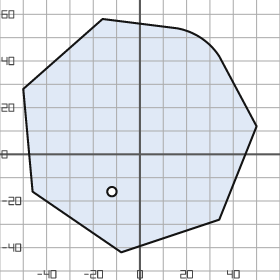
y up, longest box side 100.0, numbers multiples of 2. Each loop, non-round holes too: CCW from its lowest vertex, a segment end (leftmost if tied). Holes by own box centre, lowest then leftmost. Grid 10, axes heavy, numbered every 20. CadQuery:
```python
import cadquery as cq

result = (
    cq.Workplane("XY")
    .moveTo(-8.0, -42.0)
    .lineTo(34.0, -28.0)
    .lineTo(50.0, 12.0)
    .lineTo(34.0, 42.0)
    .threePointArc((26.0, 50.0), (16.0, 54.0))
    .lineTo(-16.0, 58.0)
    .lineTo(-50.0, 28.0)
    .lineTo(-46.0, -16.0)
    .close()
    .moveTo(-12.0, -16.0)
    .circle(2.0)
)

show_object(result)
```